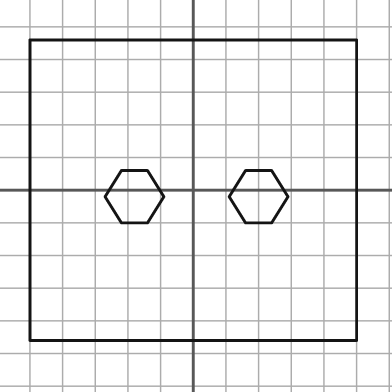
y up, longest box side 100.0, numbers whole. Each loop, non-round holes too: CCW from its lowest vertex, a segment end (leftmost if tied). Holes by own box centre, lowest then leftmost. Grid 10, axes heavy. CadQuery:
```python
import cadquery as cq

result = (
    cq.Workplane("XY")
    .moveTo(-50.0, -46.0)
    .lineTo(50.0, -46.0)
    .lineTo(50.0, 46.0)
    .lineTo(-50.0, 46.0)
    .close()
    .moveTo(-22.0, -10.0)
    .lineTo(-14.0, -10.0)
    .lineTo(-9.0, -2.0)
    .lineTo(-14.0, 6.0)
    .lineTo(-22.0, 6.0)
    .lineTo(-27.0, -2.0)
    .close()
    .moveTo(16.0, -10.0)
    .lineTo(24.0, -10.0)
    .lineTo(29.0, -2.0)
    .lineTo(24.0, 6.0)
    .lineTo(16.0, 6.0)
    .lineTo(11.0, -2.0)
    .close()
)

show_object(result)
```